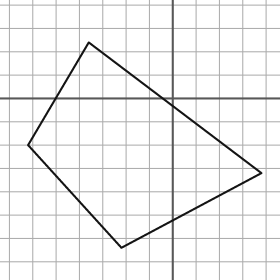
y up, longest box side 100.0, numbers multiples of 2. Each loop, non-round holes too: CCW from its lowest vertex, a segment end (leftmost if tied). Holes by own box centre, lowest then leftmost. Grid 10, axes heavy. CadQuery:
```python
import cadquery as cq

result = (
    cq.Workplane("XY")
    .moveTo(-22.0, -64.0)
    .lineTo(38.0, -32.0)
    .lineTo(-36.0, 24.0)
    .lineTo(-62.0, -20.0)
    .close()
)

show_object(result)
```